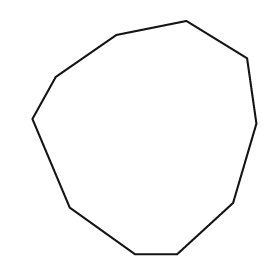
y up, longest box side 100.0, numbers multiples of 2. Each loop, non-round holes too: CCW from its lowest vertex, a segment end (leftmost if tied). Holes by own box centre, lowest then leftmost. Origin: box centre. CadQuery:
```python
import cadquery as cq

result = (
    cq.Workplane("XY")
    .moveTo(-4.0, -50.0)
    .lineTo(14.0, -50.0)
    .lineTo(38.0, -28.0)
    .lineTo(48.0, 6.0)
    .lineTo(44.0, 34.0)
    .lineTo(18.0, 50.0)
    .lineTo(-12.0, 44.0)
    .lineTo(-38.0, 26.0)
    .lineTo(-48.0, 8.0)
    .lineTo(-32.0, -30.0)
    .close()
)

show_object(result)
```